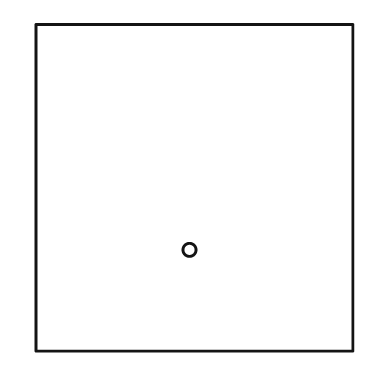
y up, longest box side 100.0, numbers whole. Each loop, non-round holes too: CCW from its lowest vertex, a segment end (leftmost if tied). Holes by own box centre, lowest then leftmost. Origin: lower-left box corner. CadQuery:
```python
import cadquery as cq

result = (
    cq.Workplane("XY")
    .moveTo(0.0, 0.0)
    .lineTo(97.0, 0.0)
    .lineTo(97.0, 100.0)
    .lineTo(0.0, 100.0)
    .close()
    .moveTo(47.0, 31.0)
    .circle(2.0)
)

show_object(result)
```